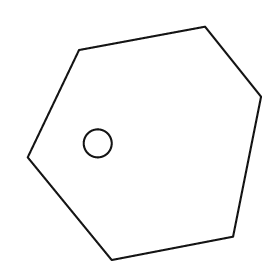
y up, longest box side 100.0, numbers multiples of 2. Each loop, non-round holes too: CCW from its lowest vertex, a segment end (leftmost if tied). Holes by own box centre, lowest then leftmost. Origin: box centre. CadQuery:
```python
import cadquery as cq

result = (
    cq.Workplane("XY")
    .moveTo(-14.0, -50.0)
    .lineTo(38.0, -40.0)
    .lineTo(50.0, 20.0)
    .lineTo(26.0, 50.0)
    .lineTo(-28.0, 40.0)
    .lineTo(-50.0, -6.0)
    .close()
    .moveTo(-20.0, 0.0)
    .circle(6.0)
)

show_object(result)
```